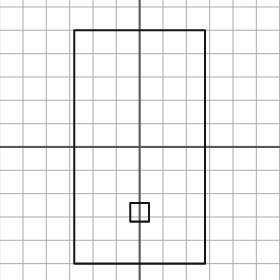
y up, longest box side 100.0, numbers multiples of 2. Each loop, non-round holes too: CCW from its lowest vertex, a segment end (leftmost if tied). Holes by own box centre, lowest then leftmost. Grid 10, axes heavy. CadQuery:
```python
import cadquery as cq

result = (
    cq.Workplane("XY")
    .moveTo(-28.0, -50.0)
    .lineTo(28.0, -50.0)
    .lineTo(28.0, 50.0)
    .lineTo(-28.0, 50.0)
    .close()
    .moveTo(-4.0, -32.0)
    .lineTo(4.0, -32.0)
    .lineTo(4.0, -24.0)
    .lineTo(-4.0, -24.0)
    .close()
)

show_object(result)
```